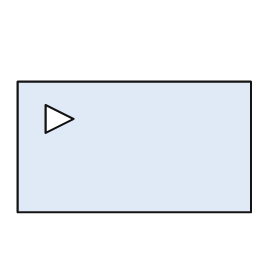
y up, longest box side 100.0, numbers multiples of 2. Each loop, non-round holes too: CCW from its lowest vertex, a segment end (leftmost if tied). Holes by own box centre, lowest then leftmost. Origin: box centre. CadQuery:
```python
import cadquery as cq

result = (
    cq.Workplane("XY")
    .moveTo(-50.0, -28.0)
    .lineTo(50.0, -28.0)
    .lineTo(50.0, 28.0)
    .lineTo(-50.0, 28.0)
    .close()
    .moveTo(-38.0, 6.0)
    .lineTo(-26.0, 12.0)
    .lineTo(-38.0, 18.0)
    .close()
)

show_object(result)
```